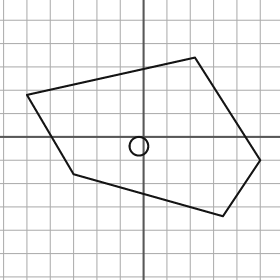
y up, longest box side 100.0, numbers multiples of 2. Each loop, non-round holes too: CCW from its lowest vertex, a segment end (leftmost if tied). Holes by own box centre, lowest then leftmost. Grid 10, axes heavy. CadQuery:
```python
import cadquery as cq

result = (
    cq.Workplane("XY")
    .moveTo(34.0, -34.0)
    .lineTo(50.0, -10.0)
    .lineTo(22.0, 34.0)
    .lineTo(-50.0, 18.0)
    .lineTo(-30.0, -16.0)
    .close()
    .moveTo(-2.0, -4.0)
    .circle(4.0)
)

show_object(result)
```